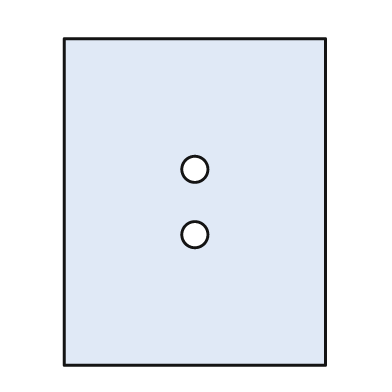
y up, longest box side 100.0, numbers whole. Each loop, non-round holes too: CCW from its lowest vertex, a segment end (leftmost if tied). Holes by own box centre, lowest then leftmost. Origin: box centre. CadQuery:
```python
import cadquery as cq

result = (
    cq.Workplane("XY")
    .moveTo(-40.0, -50.0)
    .lineTo(40.0, -50.0)
    .lineTo(40.0, 50.0)
    .lineTo(-40.0, 50.0)
    .close()
    .moveTo(0.0, -10.0)
    .circle(4.0)
    .moveTo(0.0, 10.0)
    .circle(4.0)
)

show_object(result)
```